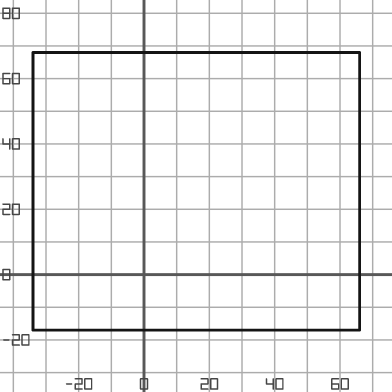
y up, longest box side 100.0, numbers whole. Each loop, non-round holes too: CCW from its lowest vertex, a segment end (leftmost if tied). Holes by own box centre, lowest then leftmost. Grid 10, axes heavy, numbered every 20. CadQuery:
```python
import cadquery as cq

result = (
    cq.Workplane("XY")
    .moveTo(-34.0, -17.0)
    .lineTo(66.0, -17.0)
    .lineTo(66.0, 68.0)
    .lineTo(-34.0, 68.0)
    .close()
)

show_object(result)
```